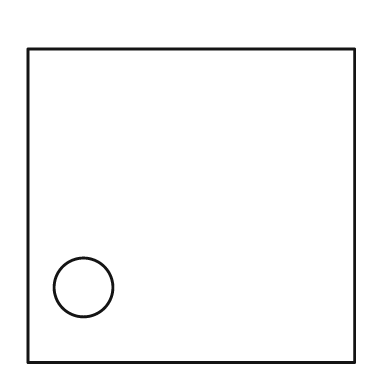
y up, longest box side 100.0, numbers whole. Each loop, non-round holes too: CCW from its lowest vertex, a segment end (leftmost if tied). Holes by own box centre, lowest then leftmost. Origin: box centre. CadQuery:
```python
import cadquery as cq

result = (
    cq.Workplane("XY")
    .moveTo(-50.0, -48.0)
    .lineTo(50.0, -48.0)
    .lineTo(50.0, 48.0)
    .lineTo(-50.0, 48.0)
    .close()
    .moveTo(-33.0, -25.0)
    .circle(9.0)
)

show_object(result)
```